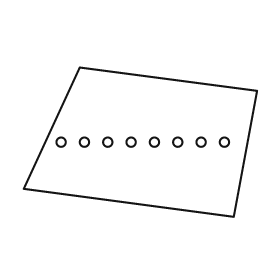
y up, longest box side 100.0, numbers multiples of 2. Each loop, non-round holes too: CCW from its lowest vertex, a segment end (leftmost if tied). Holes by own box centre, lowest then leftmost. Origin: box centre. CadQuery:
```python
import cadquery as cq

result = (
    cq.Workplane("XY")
    .moveTo(40.0, -32.0)
    .lineTo(50.0, 22.0)
    .lineTo(-26.0, 32.0)
    .lineTo(-50.0, -20.0)
    .close()
    .moveTo(-34.0, 0.0)
    .circle(2.0)
    .moveTo(-24.0, 0.0)
    .circle(2.0)
    .moveTo(-14.0, 0.0)
    .circle(2.0)
    .moveTo(-4.0, 0.0)
    .circle(2.0)
    .moveTo(6.0, 0.0)
    .circle(2.0)
    .moveTo(16.0, 0.0)
    .circle(2.0)
    .moveTo(26.0, 0.0)
    .circle(2.0)
    .moveTo(36.0, 0.0)
    .circle(2.0)
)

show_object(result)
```